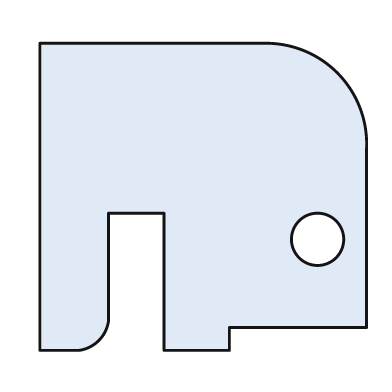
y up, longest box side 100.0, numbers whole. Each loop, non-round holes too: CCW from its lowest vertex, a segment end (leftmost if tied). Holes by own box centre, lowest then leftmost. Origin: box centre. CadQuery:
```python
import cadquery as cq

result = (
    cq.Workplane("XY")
    .moveTo(-50.0, -47.0)
    .lineTo(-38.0, -47.0)
    .threePointArc((-32.0, -44.0), (-29.0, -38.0))
    .lineTo(-29.0, -5.0)
    .lineTo(-12.0, -5.0)
    .lineTo(-12.0, -47.0)
    .lineTo(8.0, -47.0)
    .lineTo(8.0, -40.0)
    .lineTo(50.0, -40.0)
    .lineTo(50.0, 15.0)
    .threePointArc((41.0, 38.0), (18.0, 47.0))
    .lineTo(-50.0, 47.0)
    .close()
    .moveTo(35.0, -13.0)
    .circle(8.0)
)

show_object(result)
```